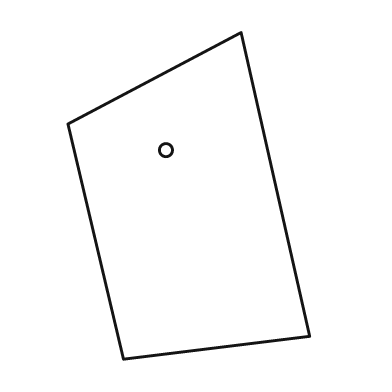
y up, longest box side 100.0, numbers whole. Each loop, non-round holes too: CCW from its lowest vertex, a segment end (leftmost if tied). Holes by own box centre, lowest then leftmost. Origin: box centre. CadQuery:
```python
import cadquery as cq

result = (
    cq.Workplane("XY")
    .moveTo(-20.0, -50.0)
    .lineTo(37.0, -43.0)
    .lineTo(16.0, 50.0)
    .lineTo(-37.0, 22.0)
    .close()
    .moveTo(-7.0, 14.0)
    .circle(2.0)
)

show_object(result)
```